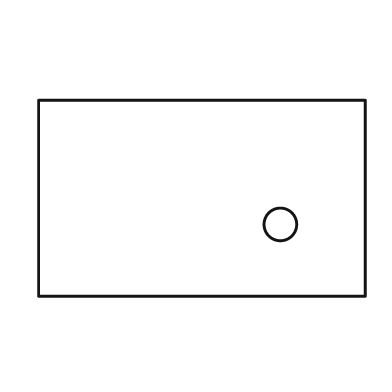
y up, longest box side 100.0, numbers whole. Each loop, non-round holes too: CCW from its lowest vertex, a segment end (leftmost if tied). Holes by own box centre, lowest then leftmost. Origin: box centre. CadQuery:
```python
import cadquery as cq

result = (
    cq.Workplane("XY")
    .moveTo(-50.0, -30.0)
    .lineTo(50.0, -30.0)
    .lineTo(50.0, 30.0)
    .lineTo(-50.0, 30.0)
    .close()
    .moveTo(24.0, -8.0)
    .circle(5.0)
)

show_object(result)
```